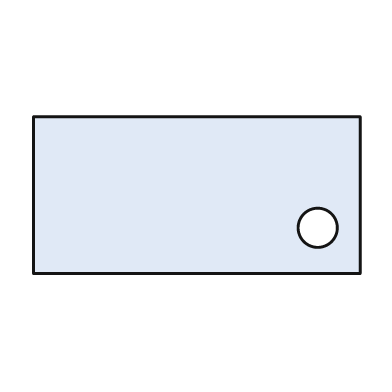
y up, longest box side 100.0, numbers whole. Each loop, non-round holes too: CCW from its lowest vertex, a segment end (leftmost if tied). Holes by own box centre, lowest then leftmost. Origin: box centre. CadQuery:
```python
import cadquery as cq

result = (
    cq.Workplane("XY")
    .moveTo(-50.0, -24.0)
    .lineTo(50.0, -24.0)
    .lineTo(50.0, 24.0)
    .lineTo(-50.0, 24.0)
    .close()
    .moveTo(37.0, -10.0)
    .circle(6.0)
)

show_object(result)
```